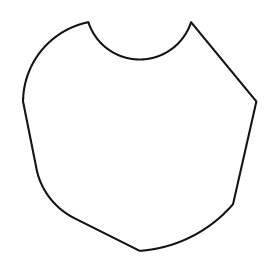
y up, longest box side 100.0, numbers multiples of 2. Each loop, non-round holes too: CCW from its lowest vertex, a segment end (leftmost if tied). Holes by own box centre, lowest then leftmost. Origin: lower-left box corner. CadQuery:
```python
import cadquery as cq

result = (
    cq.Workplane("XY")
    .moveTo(50.0, 0.0)
    .threePointArc((72.0, 6.0), (90.0, 20.0))
    .lineTo(100.0, 64.0)
    .lineTo(72.0, 98.0)
    .threePointArc((50.0, 82.0), (28.0, 98.0))
    .threePointArc((8.0, 86.0), (0.0, 64.0))
    .lineTo(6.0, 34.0)
    .threePointArc((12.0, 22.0), (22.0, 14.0))
    .close()
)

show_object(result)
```